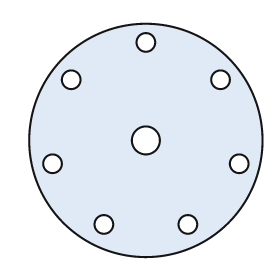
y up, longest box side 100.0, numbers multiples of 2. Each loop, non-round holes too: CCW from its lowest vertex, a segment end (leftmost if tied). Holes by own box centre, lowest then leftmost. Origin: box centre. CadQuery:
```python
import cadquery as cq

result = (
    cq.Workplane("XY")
    .moveTo(0.0, 0.0)
    .circle(50.0)
    .moveTo(-18.0, -36.0)
    .circle(4.0)
    .moveTo(18.0, -36.0)
    .circle(4.0)
    .moveTo(-40.0, -10.0)
    .circle(4.0)
    .moveTo(40.0, -10.0)
    .circle(4.0)
    .moveTo(0.0, 0.0)
    .circle(6.0)
    .moveTo(-32.0, 26.0)
    .circle(4.0)
    .moveTo(32.0, 26.0)
    .circle(4.0)
    .moveTo(0.0, 42.0)
    .circle(4.0)
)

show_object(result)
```